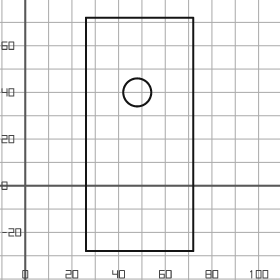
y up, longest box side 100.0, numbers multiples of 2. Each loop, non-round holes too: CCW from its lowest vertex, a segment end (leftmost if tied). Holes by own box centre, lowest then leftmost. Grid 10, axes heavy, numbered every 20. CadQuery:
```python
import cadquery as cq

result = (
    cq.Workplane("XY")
    .moveTo(26.0, -28.0)
    .lineTo(72.0, -28.0)
    .lineTo(72.0, 72.0)
    .lineTo(26.0, 72.0)
    .close()
    .moveTo(48.0, 40.0)
    .circle(6.0)
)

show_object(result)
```